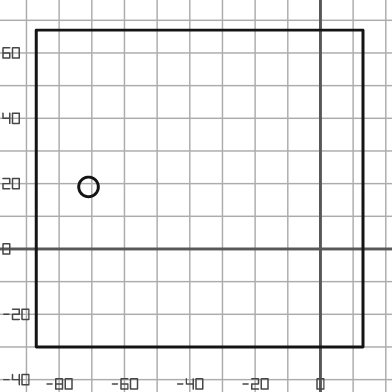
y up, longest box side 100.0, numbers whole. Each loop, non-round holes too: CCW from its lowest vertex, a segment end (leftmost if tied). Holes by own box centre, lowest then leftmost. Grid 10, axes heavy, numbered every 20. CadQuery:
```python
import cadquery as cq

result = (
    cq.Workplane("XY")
    .moveTo(-87.0, -30.0)
    .lineTo(13.0, -30.0)
    .lineTo(13.0, 67.0)
    .lineTo(-87.0, 67.0)
    .close()
    .moveTo(-71.0, 19.0)
    .circle(3.0)
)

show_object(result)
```